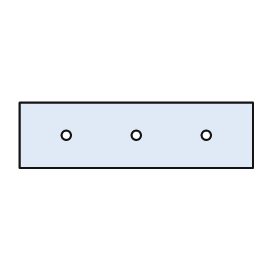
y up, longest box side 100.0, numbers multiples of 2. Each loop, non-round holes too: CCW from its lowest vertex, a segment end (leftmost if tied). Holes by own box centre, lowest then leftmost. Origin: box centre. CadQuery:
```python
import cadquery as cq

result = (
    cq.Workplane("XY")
    .moveTo(-50.0, -14.0)
    .lineTo(50.0, -14.0)
    .lineTo(50.0, 14.0)
    .lineTo(-50.0, 14.0)
    .close()
    .moveTo(-30.0, 0.0)
    .circle(2.0)
    .moveTo(0.0, 0.0)
    .circle(2.0)
    .moveTo(30.0, 0.0)
    .circle(2.0)
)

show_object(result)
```